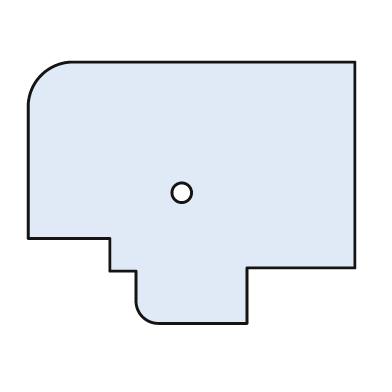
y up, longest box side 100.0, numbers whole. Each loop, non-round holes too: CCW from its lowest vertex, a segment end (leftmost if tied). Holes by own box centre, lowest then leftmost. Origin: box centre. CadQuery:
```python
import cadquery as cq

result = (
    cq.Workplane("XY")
    .moveTo(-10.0, -40.0)
    .lineTo(17.0, -40.0)
    .lineTo(17.0, -23.0)
    .lineTo(50.0, -23.0)
    .lineTo(50.0, 40.0)
    .lineTo(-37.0, 40.0)
    .threePointArc((-46.0, 36.0), (-50.0, 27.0))
    .lineTo(-50.0, -14.0)
    .lineTo(-25.0, -14.0)
    .lineTo(-25.0, -24.0)
    .lineTo(-17.0, -24.0)
    .lineTo(-17.0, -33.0)
    .threePointArc((-15.0, -38.0), (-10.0, -40.0))
    .close()
    .moveTo(-3.0, 0.0)
    .circle(3.0)
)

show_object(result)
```